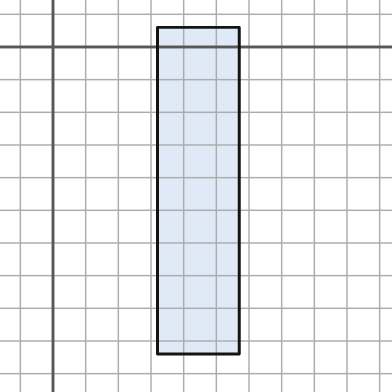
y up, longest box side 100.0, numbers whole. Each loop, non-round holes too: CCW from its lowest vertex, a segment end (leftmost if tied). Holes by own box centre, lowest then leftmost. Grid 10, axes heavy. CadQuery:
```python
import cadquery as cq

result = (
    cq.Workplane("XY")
    .moveTo(32.0, -94.0)
    .lineTo(57.0, -94.0)
    .lineTo(57.0, 6.0)
    .lineTo(32.0, 6.0)
    .close()
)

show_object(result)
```